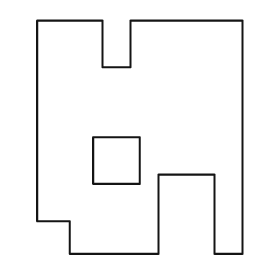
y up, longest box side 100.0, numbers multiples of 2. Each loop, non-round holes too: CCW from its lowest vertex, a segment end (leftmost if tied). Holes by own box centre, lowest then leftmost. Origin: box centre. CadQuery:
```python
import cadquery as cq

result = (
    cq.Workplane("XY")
    .moveTo(-30.0, -50.0)
    .lineTo(8.0, -50.0)
    .lineTo(8.0, -16.0)
    .lineTo(32.0, -16.0)
    .lineTo(32.0, -50.0)
    .lineTo(44.0, -50.0)
    .lineTo(44.0, 50.0)
    .lineTo(-4.0, 50.0)
    .lineTo(-4.0, 30.0)
    .lineTo(-16.0, 30.0)
    .lineTo(-16.0, 50.0)
    .lineTo(-44.0, 50.0)
    .lineTo(-44.0, -36.0)
    .lineTo(-30.0, -36.0)
    .close()
    .moveTo(-20.0, -20.0)
    .lineTo(0.0, -20.0)
    .lineTo(0.0, 0.0)
    .lineTo(-20.0, 0.0)
    .close()
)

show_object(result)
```